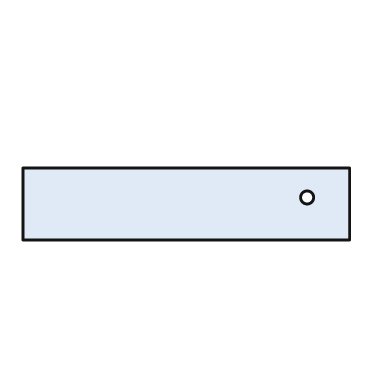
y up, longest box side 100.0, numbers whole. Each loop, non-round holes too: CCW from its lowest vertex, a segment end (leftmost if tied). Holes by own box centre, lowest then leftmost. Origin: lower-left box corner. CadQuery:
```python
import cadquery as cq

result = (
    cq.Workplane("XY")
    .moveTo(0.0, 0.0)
    .lineTo(100.0, 0.0)
    .lineTo(100.0, 22.0)
    .lineTo(0.0, 22.0)
    .close()
    .moveTo(87.0, 13.0)
    .circle(2.0)
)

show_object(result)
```